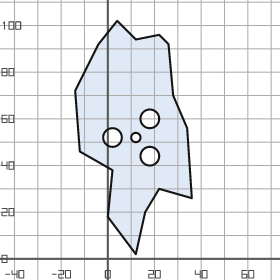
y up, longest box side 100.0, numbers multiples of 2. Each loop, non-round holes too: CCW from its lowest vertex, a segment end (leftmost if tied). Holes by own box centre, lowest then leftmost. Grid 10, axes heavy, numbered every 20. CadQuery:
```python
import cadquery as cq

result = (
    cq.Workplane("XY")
    .moveTo(12.0, 2.0)
    .lineTo(16.0, 20.0)
    .lineTo(22.0, 30.0)
    .lineTo(36.0, 26.0)
    .lineTo(34.0, 56.0)
    .lineTo(28.0, 70.0)
    .lineTo(26.0, 92.0)
    .lineTo(22.0, 96.0)
    .lineTo(12.0, 94.0)
    .lineTo(4.0, 102.0)
    .lineTo(-4.0, 92.0)
    .lineTo(-14.0, 72.0)
    .lineTo(-12.0, 46.0)
    .lineTo(2.0, 38.0)
    .lineTo(0.0, 18.0)
    .close()
    .moveTo(18.0, 44.0)
    .circle(4.0)
    .moveTo(2.0, 52.0)
    .circle(4.0)
    .moveTo(12.0, 52.0)
    .circle(2.0)
    .moveTo(18.0, 60.0)
    .circle(4.0)
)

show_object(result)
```